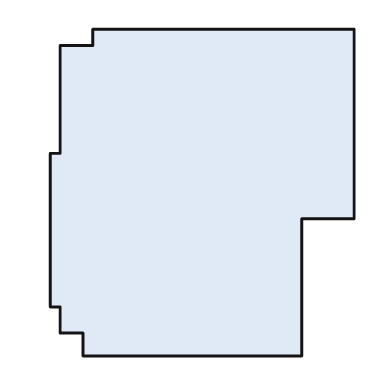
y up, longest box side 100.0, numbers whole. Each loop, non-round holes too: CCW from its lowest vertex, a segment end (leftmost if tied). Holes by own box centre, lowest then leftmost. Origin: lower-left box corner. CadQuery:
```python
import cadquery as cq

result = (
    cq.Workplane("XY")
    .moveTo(10.0, 0.0)
    .lineTo(77.0, 0.0)
    .lineTo(77.0, 42.0)
    .lineTo(93.0, 42.0)
    .lineTo(93.0, 100.0)
    .lineTo(13.0, 100.0)
    .lineTo(13.0, 95.0)
    .lineTo(3.0, 95.0)
    .lineTo(3.0, 62.0)
    .lineTo(0.0, 62.0)
    .lineTo(0.0, 15.0)
    .lineTo(3.0, 15.0)
    .lineTo(3.0, 7.0)
    .lineTo(10.0, 7.0)
    .close()
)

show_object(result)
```